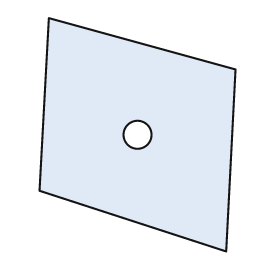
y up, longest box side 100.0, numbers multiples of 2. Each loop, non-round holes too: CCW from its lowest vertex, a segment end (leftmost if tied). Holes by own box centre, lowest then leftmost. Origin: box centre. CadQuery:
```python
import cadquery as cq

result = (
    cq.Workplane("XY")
    .moveTo(38.0, -50.0)
    .lineTo(42.0, 28.0)
    .lineTo(-38.0, 50.0)
    .lineTo(-42.0, -24.0)
    .close()
    .moveTo(0.0, 0.0)
    .circle(6.0)
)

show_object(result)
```